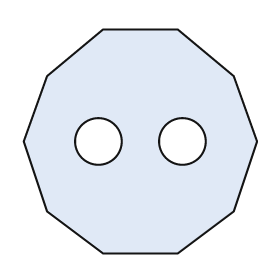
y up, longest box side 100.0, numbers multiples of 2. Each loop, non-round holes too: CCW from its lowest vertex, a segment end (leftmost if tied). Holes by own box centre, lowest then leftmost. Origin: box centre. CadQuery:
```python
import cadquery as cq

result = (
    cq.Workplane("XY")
    .moveTo(-16.0, -48.0)
    .lineTo(16.0, -48.0)
    .lineTo(40.0, -30.0)
    .lineTo(50.0, 0.0)
    .lineTo(40.0, 28.0)
    .lineTo(16.0, 48.0)
    .lineTo(-16.0, 48.0)
    .lineTo(-40.0, 28.0)
    .lineTo(-50.0, 0.0)
    .lineTo(-40.0, -30.0)
    .close()
    .moveTo(-18.0, 0.0)
    .circle(10.0)
    .moveTo(18.0, 0.0)
    .circle(10.0)
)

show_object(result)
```